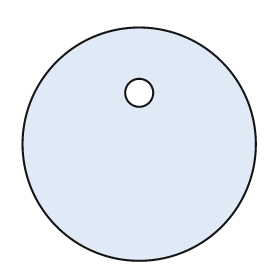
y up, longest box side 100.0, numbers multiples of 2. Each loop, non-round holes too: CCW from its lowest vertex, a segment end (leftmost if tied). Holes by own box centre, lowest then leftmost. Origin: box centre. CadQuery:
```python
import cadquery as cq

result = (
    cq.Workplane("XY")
    .moveTo(0.0, 0.0)
    .circle(50.0)
    .moveTo(0.0, 22.0)
    .circle(6.0)
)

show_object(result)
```